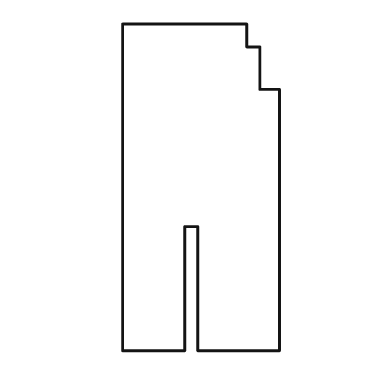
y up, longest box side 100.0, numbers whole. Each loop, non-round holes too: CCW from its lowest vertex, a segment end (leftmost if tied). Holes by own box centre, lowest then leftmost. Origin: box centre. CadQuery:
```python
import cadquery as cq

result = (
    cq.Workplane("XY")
    .moveTo(-24.0, -50.0)
    .lineTo(-5.0, -50.0)
    .lineTo(-5.0, -12.0)
    .lineTo(-1.0, -12.0)
    .lineTo(-1.0, -50.0)
    .lineTo(24.0, -50.0)
    .lineTo(24.0, 30.0)
    .lineTo(18.0, 30.0)
    .lineTo(18.0, 43.0)
    .lineTo(14.0, 43.0)
    .lineTo(14.0, 50.0)
    .lineTo(-24.0, 50.0)
    .close()
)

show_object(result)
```